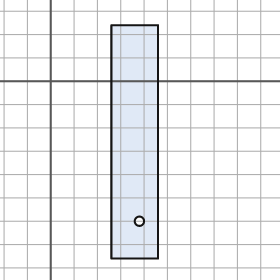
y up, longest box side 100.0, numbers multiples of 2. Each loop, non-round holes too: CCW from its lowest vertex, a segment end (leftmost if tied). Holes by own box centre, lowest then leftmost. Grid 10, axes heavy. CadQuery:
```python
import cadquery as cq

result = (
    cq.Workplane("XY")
    .moveTo(26.0, -76.0)
    .lineTo(46.0, -76.0)
    .lineTo(46.0, 24.0)
    .lineTo(26.0, 24.0)
    .close()
    .moveTo(38.0, -60.0)
    .circle(2.0)
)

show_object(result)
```